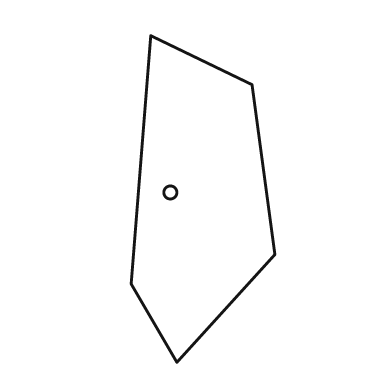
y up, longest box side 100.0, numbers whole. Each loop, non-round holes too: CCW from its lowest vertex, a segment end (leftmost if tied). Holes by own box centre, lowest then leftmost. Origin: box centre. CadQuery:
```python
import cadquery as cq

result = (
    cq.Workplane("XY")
    .moveTo(-8.0, -50.0)
    .lineTo(22.0, -17.0)
    .lineTo(15.0, 35.0)
    .lineTo(-16.0, 50.0)
    .lineTo(-22.0, -26.0)
    .close()
    .moveTo(-10.0, 2.0)
    .circle(2.0)
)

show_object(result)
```